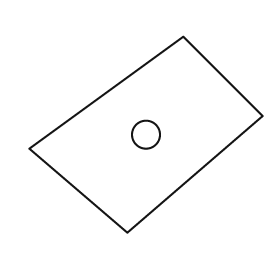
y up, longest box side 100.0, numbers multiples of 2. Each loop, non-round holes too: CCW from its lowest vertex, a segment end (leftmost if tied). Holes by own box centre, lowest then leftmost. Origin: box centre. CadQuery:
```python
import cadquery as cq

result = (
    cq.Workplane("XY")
    .moveTo(-8.0, -42.0)
    .lineTo(50.0, 8.0)
    .lineTo(16.0, 42.0)
    .lineTo(-50.0, -6.0)
    .close()
    .moveTo(0.0, 0.0)
    .circle(6.0)
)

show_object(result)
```